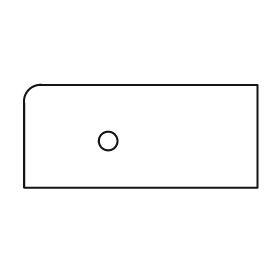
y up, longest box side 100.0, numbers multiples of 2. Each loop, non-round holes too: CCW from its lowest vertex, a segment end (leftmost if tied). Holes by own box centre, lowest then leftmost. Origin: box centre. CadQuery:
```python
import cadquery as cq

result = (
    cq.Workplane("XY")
    .moveTo(-50.0, -22.0)
    .lineTo(50.0, -22.0)
    .lineTo(50.0, 22.0)
    .lineTo(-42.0, 22.0)
    .threePointArc((-48.0, 20.0), (-50.0, 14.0))
    .close()
    .moveTo(-14.0, -2.0)
    .circle(4.0)
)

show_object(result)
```